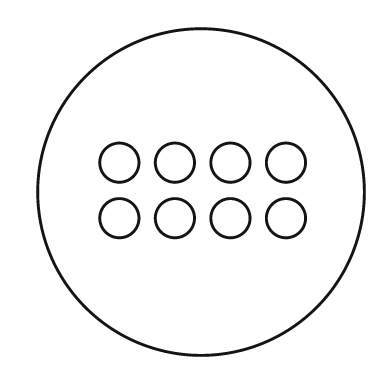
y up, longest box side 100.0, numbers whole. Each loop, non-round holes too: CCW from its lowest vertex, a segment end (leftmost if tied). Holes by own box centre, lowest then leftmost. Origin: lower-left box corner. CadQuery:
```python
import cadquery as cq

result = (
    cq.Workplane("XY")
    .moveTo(50.0, 50.0)
    .circle(50.0)
    .moveTo(25.0, 42.0)
    .circle(6.0)
    .moveTo(42.0, 42.0)
    .circle(6.0)
    .moveTo(59.0, 42.0)
    .circle(6.0)
    .moveTo(76.0, 42.0)
    .circle(6.0)
    .moveTo(25.0, 59.0)
    .circle(6.0)
    .moveTo(42.0, 59.0)
    .circle(6.0)
    .moveTo(59.0, 59.0)
    .circle(6.0)
    .moveTo(76.0, 59.0)
    .circle(6.0)
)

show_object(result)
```